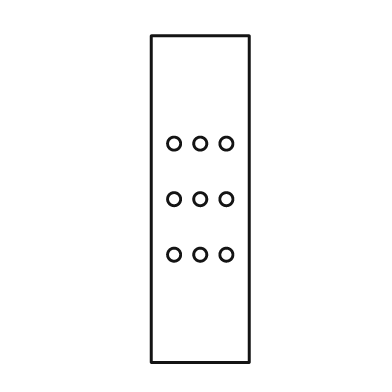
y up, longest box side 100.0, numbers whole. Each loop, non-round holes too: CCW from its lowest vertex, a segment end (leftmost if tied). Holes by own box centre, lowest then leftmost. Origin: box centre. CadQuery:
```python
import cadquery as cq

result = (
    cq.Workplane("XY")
    .moveTo(-15.0, -50.0)
    .lineTo(15.0, -50.0)
    .lineTo(15.0, 50.0)
    .lineTo(-15.0, 50.0)
    .close()
    .moveTo(-8.0, -17.0)
    .circle(2.0)
    .moveTo(0.0, -17.0)
    .circle(2.0)
    .moveTo(8.0, -17.0)
    .circle(2.0)
    .moveTo(-8.0, 0.0)
    .circle(2.0)
    .moveTo(0.0, 0.0)
    .circle(2.0)
    .moveTo(8.0, 0.0)
    .circle(2.0)
    .moveTo(-8.0, 17.0)
    .circle(2.0)
    .moveTo(0.0, 17.0)
    .circle(2.0)
    .moveTo(8.0, 17.0)
    .circle(2.0)
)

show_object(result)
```